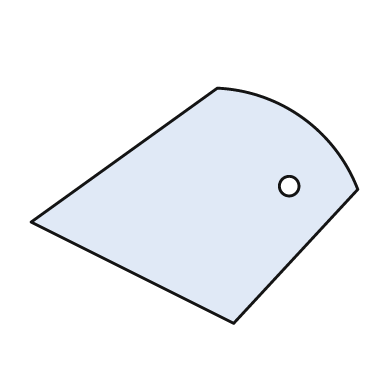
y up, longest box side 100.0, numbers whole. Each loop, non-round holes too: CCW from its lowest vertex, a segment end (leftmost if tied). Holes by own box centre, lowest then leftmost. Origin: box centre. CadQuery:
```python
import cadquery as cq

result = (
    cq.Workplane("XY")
    .moveTo(12.0, -36.0)
    .lineTo(50.0, 5.0)
    .threePointArc((33.0, 27.0), (7.0, 36.0))
    .lineTo(-50.0, -5.0)
    .close()
    .moveTo(29.0, 6.0)
    .circle(3.0)
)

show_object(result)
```